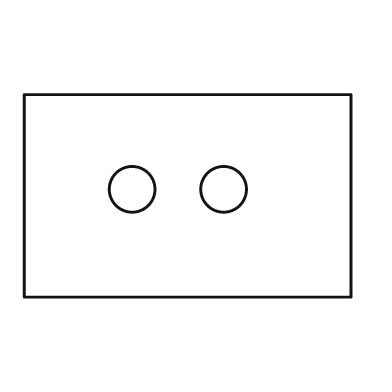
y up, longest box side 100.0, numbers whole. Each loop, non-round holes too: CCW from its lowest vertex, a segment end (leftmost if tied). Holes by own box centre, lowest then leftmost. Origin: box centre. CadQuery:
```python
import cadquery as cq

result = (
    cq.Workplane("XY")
    .moveTo(-50.0, -31.0)
    .lineTo(50.0, -31.0)
    .lineTo(50.0, 31.0)
    .lineTo(-50.0, 31.0)
    .close()
    .moveTo(-17.0, 2.0)
    .circle(7.0)
    .moveTo(11.0, 2.0)
    .circle(7.0)
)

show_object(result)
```